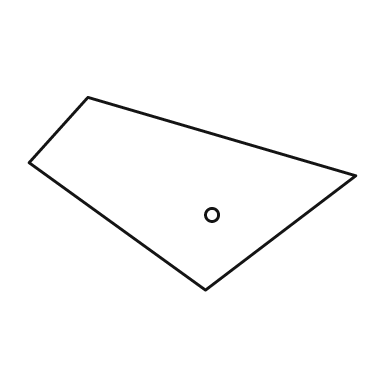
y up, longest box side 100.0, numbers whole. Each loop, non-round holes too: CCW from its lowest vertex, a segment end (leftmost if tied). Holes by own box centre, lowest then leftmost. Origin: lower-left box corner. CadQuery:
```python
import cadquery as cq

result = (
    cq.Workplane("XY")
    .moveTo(54.0, 0.0)
    .lineTo(100.0, 35.0)
    .lineTo(18.0, 59.0)
    .lineTo(0.0, 39.0)
    .close()
    .moveTo(56.0, 23.0)
    .circle(2.0)
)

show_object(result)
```